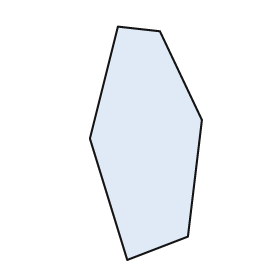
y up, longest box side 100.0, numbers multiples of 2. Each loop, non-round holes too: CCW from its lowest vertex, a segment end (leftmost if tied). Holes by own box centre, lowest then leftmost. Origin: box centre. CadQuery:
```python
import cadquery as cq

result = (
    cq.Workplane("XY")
    .moveTo(-8.0, -50.0)
    .lineTo(18.0, -40.0)
    .lineTo(24.0, 10.0)
    .lineTo(6.0, 48.0)
    .lineTo(-12.0, 50.0)
    .lineTo(-24.0, 2.0)
    .close()
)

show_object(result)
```